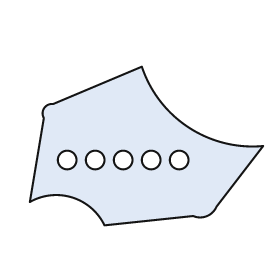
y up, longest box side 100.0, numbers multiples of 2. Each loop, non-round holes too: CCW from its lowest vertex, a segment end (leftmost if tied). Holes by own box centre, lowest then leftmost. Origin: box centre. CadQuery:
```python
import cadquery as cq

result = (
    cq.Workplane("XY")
    .moveTo(-18.0, -34.0)
    .lineTo(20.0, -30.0)
    .threePointArc((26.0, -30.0), (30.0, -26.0))
    .lineTo(50.0, 0.0)
    .threePointArc((18.0, 8.0), (-2.0, 34.0))
    .lineTo(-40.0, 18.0)
    .threePointArc((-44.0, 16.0), (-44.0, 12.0))
    .lineTo(-50.0, -24.0)
    .threePointArc((-32.0, -22.0), (-18.0, -34.0))
    .close()
    .moveTo(-34.0, -6.0)
    .circle(4.0)
    .moveTo(-22.0, -6.0)
    .circle(4.0)
    .moveTo(-10.0, -6.0)
    .circle(4.0)
    .moveTo(2.0, -6.0)
    .circle(4.0)
    .moveTo(14.0, -6.0)
    .circle(4.0)
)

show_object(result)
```